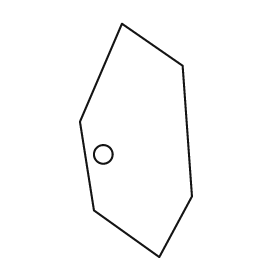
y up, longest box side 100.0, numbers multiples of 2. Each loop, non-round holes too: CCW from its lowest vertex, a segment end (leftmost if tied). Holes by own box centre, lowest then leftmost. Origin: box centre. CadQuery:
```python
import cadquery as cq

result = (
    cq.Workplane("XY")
    .moveTo(10.0, -50.0)
    .lineTo(24.0, -24.0)
    .lineTo(20.0, 32.0)
    .lineTo(-6.0, 50.0)
    .lineTo(-24.0, 8.0)
    .lineTo(-18.0, -30.0)
    .close()
    .moveTo(-14.0, -6.0)
    .circle(4.0)
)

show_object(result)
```